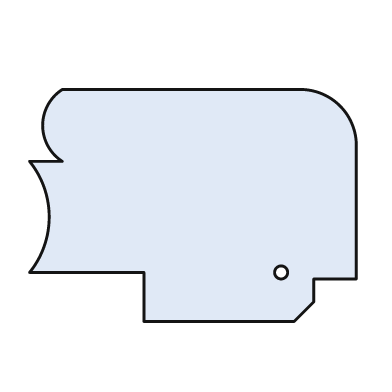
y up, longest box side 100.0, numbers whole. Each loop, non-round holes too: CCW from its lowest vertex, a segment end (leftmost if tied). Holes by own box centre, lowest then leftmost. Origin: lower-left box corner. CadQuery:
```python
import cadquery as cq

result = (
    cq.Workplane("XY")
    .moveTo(35.0, 0.0)
    .lineTo(81.0, 0.0)
    .lineTo(87.0, 6.0)
    .lineTo(87.0, 13.0)
    .lineTo(100.0, 13.0)
    .lineTo(100.0, 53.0)
    .threePointArc((95.0, 66.0), (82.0, 71.0))
    .lineTo(10.0, 71.0)
    .threePointArc((4.0, 60.0), (10.0, 49.0))
    .lineTo(0.0, 49.0)
    .threePointArc((6.0, 32.0), (0.0, 15.0))
    .lineTo(35.0, 15.0)
    .close()
    .moveTo(77.0, 15.0)
    .circle(2.0)
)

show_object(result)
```